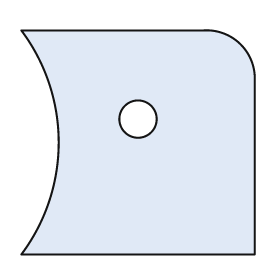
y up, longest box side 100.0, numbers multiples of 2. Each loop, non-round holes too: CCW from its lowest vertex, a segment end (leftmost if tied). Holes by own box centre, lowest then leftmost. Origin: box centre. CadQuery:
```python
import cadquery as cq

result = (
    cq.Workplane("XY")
    .moveTo(-50.0, -48.0)
    .lineTo(50.0, -48.0)
    .lineTo(50.0, 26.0)
    .threePointArc((44.0, 42.0), (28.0, 48.0))
    .lineTo(-50.0, 48.0)
    .threePointArc((-34.0, 0.0), (-50.0, -48.0))
    .close()
    .moveTo(0.0, 10.0)
    .circle(8.0)
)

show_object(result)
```